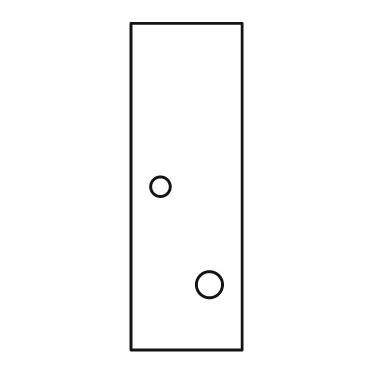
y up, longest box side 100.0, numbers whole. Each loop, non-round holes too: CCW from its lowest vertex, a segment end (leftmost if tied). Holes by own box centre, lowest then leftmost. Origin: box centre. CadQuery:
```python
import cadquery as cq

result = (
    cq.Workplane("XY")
    .moveTo(-17.0, -50.0)
    .lineTo(17.0, -50.0)
    .lineTo(17.0, 50.0)
    .lineTo(-17.0, 50.0)
    .close()
    .moveTo(7.0, -30.0)
    .circle(4.0)
    .moveTo(-8.0, 0.0)
    .circle(3.0)
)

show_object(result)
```